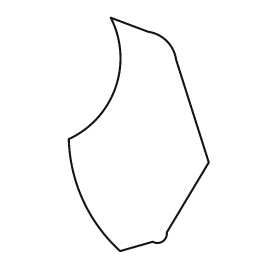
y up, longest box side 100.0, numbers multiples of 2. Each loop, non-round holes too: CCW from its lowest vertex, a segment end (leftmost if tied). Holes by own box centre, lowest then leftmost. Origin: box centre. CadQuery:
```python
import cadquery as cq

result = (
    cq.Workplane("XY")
    .moveTo(-8.0, -50.0)
    .lineTo(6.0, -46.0)
    .threePointArc((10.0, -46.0), (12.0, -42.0))
    .lineTo(30.0, -12.0)
    .lineTo(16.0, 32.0)
    .threePointArc((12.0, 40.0), (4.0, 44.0))
    .lineTo(-12.0, 50.0)
    .threePointArc((-10.0, 20.0), (-30.0, -2.0))
    .threePointArc((-24.0, -28.0), (-8.0, -50.0))
    .close()
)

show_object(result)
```